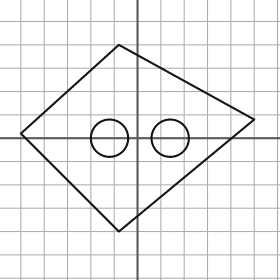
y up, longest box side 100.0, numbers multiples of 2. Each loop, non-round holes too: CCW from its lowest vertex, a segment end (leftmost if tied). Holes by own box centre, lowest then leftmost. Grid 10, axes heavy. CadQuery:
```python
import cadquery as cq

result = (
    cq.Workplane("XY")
    .moveTo(-8.0, -40.0)
    .lineTo(50.0, 8.0)
    .lineTo(-8.0, 40.0)
    .lineTo(-50.0, 2.0)
    .close()
    .moveTo(-12.0, 0.0)
    .circle(8.0)
    .moveTo(14.0, 0.0)
    .circle(8.0)
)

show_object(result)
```